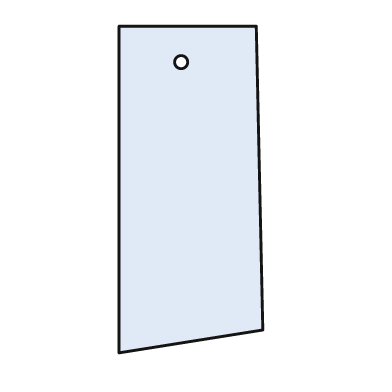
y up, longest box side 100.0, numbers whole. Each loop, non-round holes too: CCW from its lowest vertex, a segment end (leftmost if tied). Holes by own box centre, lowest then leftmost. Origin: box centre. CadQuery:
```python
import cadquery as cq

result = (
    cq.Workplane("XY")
    .moveTo(-22.0, -50.0)
    .lineTo(22.0, -43.0)
    .lineTo(20.0, 50.0)
    .lineTo(-22.0, 50.0)
    .close()
    .moveTo(-3.0, 39.0)
    .circle(2.0)
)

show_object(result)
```